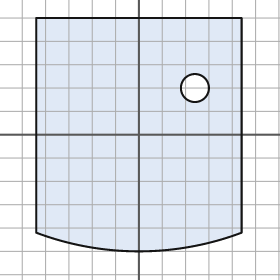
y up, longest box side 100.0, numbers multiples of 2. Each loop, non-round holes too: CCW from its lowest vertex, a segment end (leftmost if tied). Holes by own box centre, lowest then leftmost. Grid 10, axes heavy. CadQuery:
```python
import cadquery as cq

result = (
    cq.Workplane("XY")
    .moveTo(-44.0, -42.0)
    .threePointArc((0.0, -50.0), (44.0, -42.0))
    .lineTo(44.0, 50.0)
    .lineTo(-44.0, 50.0)
    .close()
    .moveTo(24.0, 20.0)
    .circle(6.0)
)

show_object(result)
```